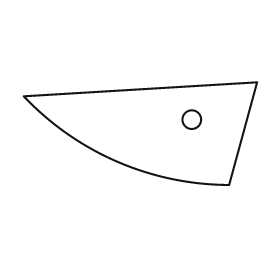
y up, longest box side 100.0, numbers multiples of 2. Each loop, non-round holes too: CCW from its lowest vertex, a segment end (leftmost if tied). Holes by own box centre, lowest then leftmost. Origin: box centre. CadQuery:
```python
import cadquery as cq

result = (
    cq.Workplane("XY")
    .moveTo(38.0, -22.0)
    .lineTo(50.0, 22.0)
    .lineTo(-50.0, 16.0)
    .threePointArc((-10.0, -12.0), (38.0, -22.0))
    .close()
    .moveTo(22.0, 6.0)
    .circle(4.0)
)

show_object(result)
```